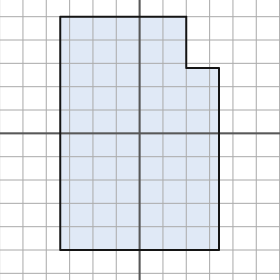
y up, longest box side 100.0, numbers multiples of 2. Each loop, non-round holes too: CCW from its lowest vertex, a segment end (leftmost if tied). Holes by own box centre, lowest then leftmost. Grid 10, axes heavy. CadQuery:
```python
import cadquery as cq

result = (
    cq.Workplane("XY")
    .moveTo(-34.0, -50.0)
    .lineTo(34.0, -50.0)
    .lineTo(34.0, 28.0)
    .lineTo(20.0, 28.0)
    .lineTo(20.0, 50.0)
    .lineTo(-34.0, 50.0)
    .close()
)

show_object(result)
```